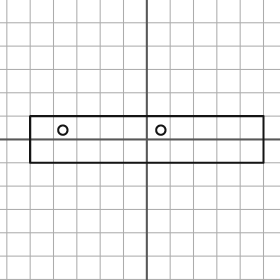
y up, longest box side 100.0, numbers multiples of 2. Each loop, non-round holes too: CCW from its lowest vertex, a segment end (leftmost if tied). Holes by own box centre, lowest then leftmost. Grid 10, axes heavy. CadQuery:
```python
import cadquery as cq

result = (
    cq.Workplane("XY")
    .moveTo(-50.0, -10.0)
    .lineTo(50.0, -10.0)
    .lineTo(50.0, 10.0)
    .lineTo(-50.0, 10.0)
    .close()
    .moveTo(-36.0, 4.0)
    .circle(2.0)
    .moveTo(6.0, 4.0)
    .circle(2.0)
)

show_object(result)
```